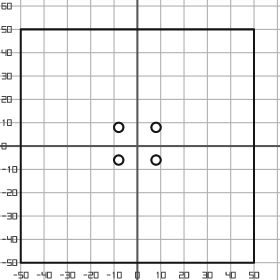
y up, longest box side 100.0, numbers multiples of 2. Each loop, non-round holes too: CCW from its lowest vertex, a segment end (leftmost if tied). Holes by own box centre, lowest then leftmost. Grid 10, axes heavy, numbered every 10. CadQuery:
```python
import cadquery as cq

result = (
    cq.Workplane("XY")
    .moveTo(-50.0, -50.0)
    .lineTo(50.0, -50.0)
    .lineTo(50.0, 50.0)
    .lineTo(-50.0, 50.0)
    .close()
    .moveTo(-8.0, -6.0)
    .circle(2.0)
    .moveTo(8.0, -6.0)
    .circle(2.0)
    .moveTo(-8.0, 8.0)
    .circle(2.0)
    .moveTo(8.0, 8.0)
    .circle(2.0)
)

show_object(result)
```